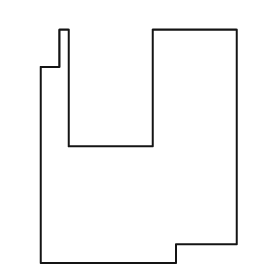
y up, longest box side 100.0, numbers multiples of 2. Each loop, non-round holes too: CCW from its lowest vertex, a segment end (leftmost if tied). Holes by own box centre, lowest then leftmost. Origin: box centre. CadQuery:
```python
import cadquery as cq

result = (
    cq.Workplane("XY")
    .moveTo(-42.0, -50.0)
    .lineTo(16.0, -50.0)
    .lineTo(16.0, -42.0)
    .lineTo(42.0, -42.0)
    .lineTo(42.0, 50.0)
    .lineTo(6.0, 50.0)
    .lineTo(6.0, 0.0)
    .lineTo(-30.0, 0.0)
    .lineTo(-30.0, 50.0)
    .lineTo(-34.0, 50.0)
    .lineTo(-34.0, 34.0)
    .lineTo(-42.0, 34.0)
    .close()
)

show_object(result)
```